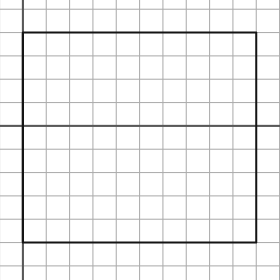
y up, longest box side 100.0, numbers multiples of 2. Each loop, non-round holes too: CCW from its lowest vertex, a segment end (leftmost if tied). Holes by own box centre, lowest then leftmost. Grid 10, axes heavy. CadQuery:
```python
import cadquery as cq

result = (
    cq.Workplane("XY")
    .moveTo(0.0, -50.0)
    .lineTo(100.0, -50.0)
    .lineTo(100.0, 40.0)
    .lineTo(0.0, 40.0)
    .close()
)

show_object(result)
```